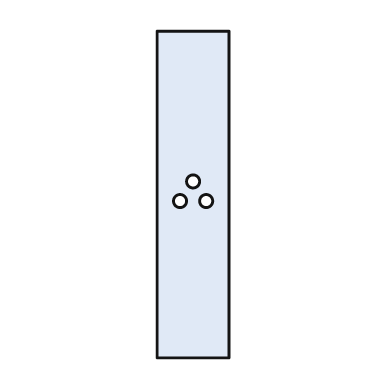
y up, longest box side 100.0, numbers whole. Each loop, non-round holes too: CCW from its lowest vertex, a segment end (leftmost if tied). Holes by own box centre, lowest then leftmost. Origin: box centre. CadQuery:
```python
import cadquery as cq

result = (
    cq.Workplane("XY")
    .moveTo(-11.0, -50.0)
    .lineTo(11.0, -50.0)
    .lineTo(11.0, 50.0)
    .lineTo(-11.0, 50.0)
    .close()
    .moveTo(-4.0, -2.0)
    .circle(2.0)
    .moveTo(4.0, -2.0)
    .circle(2.0)
    .moveTo(0.0, 4.0)
    .circle(2.0)
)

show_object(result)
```